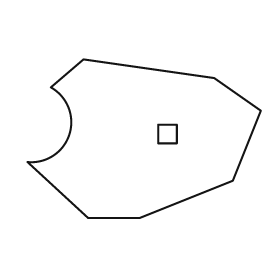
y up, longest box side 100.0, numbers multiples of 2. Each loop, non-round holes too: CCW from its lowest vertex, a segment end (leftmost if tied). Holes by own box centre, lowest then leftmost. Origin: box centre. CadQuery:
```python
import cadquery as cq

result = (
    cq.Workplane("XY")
    .moveTo(-24.0, -34.0)
    .lineTo(-2.0, -34.0)
    .lineTo(38.0, -18.0)
    .lineTo(50.0, 12.0)
    .lineTo(30.0, 26.0)
    .lineTo(-26.0, 34.0)
    .lineTo(-40.0, 22.0)
    .threePointArc((-32.0, 2.0), (-50.0, -10.0))
    .close()
    .moveTo(6.0, -2.0)
    .lineTo(14.0, -2.0)
    .lineTo(14.0, 6.0)
    .lineTo(6.0, 6.0)
    .close()
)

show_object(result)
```